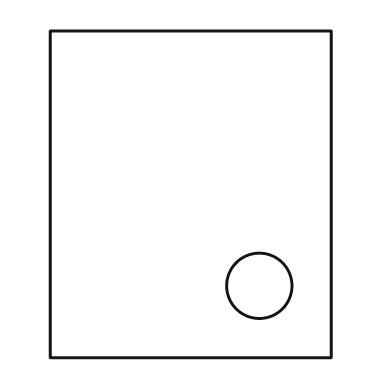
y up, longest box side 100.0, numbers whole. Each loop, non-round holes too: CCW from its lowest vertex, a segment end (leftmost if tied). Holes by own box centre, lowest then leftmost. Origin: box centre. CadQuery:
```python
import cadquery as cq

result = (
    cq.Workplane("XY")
    .moveTo(-43.0, -50.0)
    .lineTo(43.0, -50.0)
    .lineTo(43.0, 50.0)
    .lineTo(-43.0, 50.0)
    .close()
    .moveTo(21.0, -28.0)
    .circle(10.0)
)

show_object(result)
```